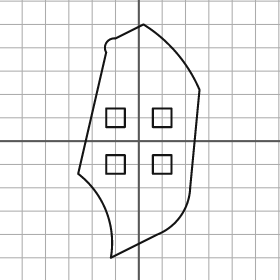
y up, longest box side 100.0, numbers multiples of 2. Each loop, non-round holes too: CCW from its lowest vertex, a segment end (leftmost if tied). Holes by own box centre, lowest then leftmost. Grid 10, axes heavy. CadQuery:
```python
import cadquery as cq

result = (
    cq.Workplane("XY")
    .moveTo(-12.0, -50.0)
    .lineTo(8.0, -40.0)
    .threePointArc((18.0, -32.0), (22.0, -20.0))
    .lineTo(26.0, 22.0)
    .threePointArc((16.0, 38.0), (2.0, 50.0))
    .lineTo(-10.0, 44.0)
    .threePointArc((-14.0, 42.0), (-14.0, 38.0))
    .lineTo(-26.0, -14.0)
    .threePointArc((-14.0, -30.0), (-12.0, -50.0))
    .close()
    .moveTo(-14.0, -14.0)
    .lineTo(-6.0, -14.0)
    .lineTo(-6.0, -6.0)
    .lineTo(-14.0, -6.0)
    .close()
    .moveTo(6.0, -14.0)
    .lineTo(14.0, -14.0)
    .lineTo(14.0, -6.0)
    .lineTo(6.0, -6.0)
    .close()
    .moveTo(-14.0, 6.0)
    .lineTo(-6.0, 6.0)
    .lineTo(-6.0, 14.0)
    .lineTo(-14.0, 14.0)
    .close()
    .moveTo(6.0, 6.0)
    .lineTo(14.0, 6.0)
    .lineTo(14.0, 14.0)
    .lineTo(6.0, 14.0)
    .close()
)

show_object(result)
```